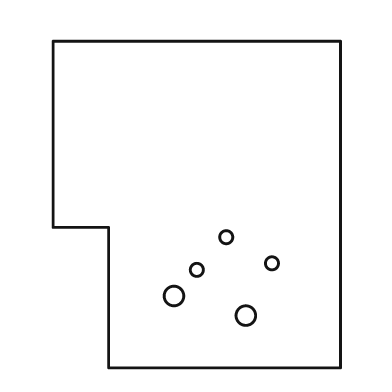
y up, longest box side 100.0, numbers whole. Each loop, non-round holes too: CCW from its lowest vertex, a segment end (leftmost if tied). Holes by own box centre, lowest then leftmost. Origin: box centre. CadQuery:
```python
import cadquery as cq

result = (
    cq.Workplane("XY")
    .moveTo(-27.0, -50.0)
    .lineTo(44.0, -50.0)
    .lineTo(44.0, 50.0)
    .lineTo(-44.0, 50.0)
    .lineTo(-44.0, -7.0)
    .lineTo(-27.0, -7.0)
    .close()
    .moveTo(15.0, -34.0)
    .circle(3.0)
    .moveTo(-7.0, -28.0)
    .circle(3.0)
    .moveTo(0.0, -20.0)
    .circle(2.0)
    .moveTo(23.0, -18.0)
    .circle(2.0)
    .moveTo(9.0, -10.0)
    .circle(2.0)
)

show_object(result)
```